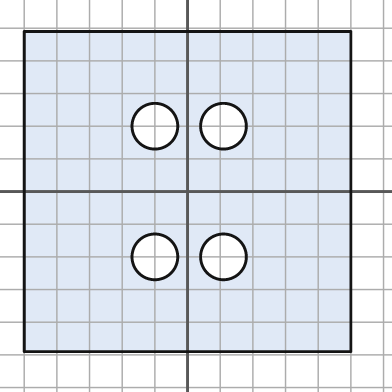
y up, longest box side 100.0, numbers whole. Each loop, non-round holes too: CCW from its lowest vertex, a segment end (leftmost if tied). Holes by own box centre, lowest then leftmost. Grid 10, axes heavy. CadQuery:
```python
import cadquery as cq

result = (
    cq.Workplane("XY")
    .moveTo(-50.0, -49.0)
    .lineTo(50.0, -49.0)
    .lineTo(50.0, 49.0)
    .lineTo(-50.0, 49.0)
    .close()
    .moveTo(-10.0, -20.0)
    .circle(7.0)
    .moveTo(11.0, -20.0)
    .circle(7.0)
    .moveTo(-10.0, 20.0)
    .circle(7.0)
    .moveTo(11.0, 20.0)
    .circle(7.0)
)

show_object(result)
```